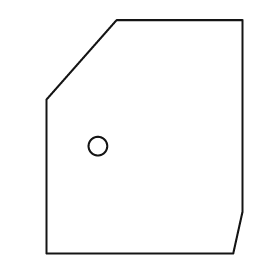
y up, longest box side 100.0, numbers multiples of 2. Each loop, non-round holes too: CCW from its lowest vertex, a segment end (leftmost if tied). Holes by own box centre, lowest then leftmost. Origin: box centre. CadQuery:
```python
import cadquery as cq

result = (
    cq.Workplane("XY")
    .moveTo(-42.0, -50.0)
    .lineTo(38.0, -50.0)
    .lineTo(42.0, -32.0)
    .lineTo(42.0, 50.0)
    .lineTo(-12.0, 50.0)
    .lineTo(-42.0, 16.0)
    .close()
    .moveTo(-20.0, -4.0)
    .circle(4.0)
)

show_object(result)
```